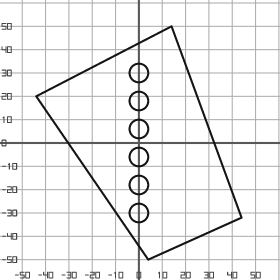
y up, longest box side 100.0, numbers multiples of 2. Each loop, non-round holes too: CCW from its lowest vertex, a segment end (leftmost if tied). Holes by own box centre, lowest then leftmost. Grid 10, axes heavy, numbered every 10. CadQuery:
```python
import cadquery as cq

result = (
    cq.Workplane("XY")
    .moveTo(4.0, -50.0)
    .lineTo(44.0, -32.0)
    .lineTo(14.0, 50.0)
    .lineTo(-44.0, 20.0)
    .close()
    .moveTo(0.0, -30.0)
    .circle(4.0)
    .moveTo(0.0, -18.0)
    .circle(4.0)
    .moveTo(0.0, -6.0)
    .circle(4.0)
    .moveTo(0.0, 6.0)
    .circle(4.0)
    .moveTo(0.0, 18.0)
    .circle(4.0)
    .moveTo(0.0, 30.0)
    .circle(4.0)
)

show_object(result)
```